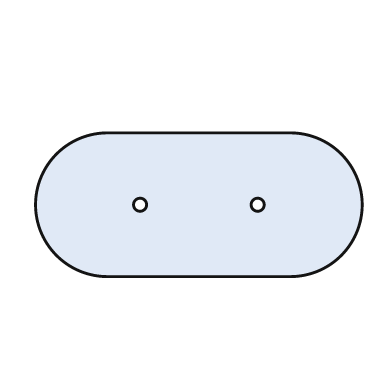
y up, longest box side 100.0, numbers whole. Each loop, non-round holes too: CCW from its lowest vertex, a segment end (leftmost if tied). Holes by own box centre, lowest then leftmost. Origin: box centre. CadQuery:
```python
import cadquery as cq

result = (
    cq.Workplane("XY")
    .moveTo(-28.0, -22.0)
    .lineTo(28.0, -22.0)
    .threePointArc((50.0, 0.0), (28.0, 22.0))
    .lineTo(-28.0, 22.0)
    .threePointArc((-50.0, 0.0), (-28.0, -22.0))
    .close()
    .moveTo(-18.0, 0.0)
    .circle(2.0)
    .moveTo(18.0, 0.0)
    .circle(2.0)
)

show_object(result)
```